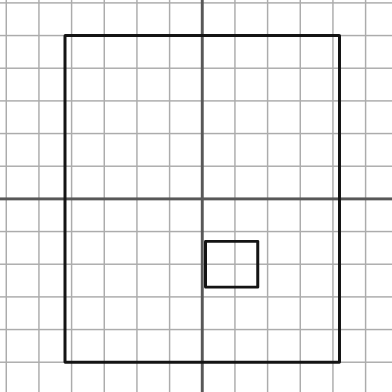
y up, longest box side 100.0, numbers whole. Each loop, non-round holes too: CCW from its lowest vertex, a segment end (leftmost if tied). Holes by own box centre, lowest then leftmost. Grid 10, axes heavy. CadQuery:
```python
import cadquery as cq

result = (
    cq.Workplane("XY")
    .moveTo(-42.0, -50.0)
    .lineTo(42.0, -50.0)
    .lineTo(42.0, 50.0)
    .lineTo(-42.0, 50.0)
    .close()
    .moveTo(1.0, -27.0)
    .lineTo(17.0, -27.0)
    .lineTo(17.0, -13.0)
    .lineTo(1.0, -13.0)
    .close()
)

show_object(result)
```